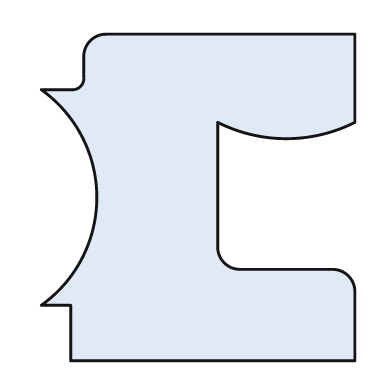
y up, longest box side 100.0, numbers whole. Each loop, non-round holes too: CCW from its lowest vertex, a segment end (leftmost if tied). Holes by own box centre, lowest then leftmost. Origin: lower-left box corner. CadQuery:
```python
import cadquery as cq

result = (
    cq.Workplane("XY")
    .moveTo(9.0, 0.0)
    .lineTo(96.0, 0.0)
    .lineTo(96.0, 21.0)
    .threePointArc((94.0, 26.0), (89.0, 28.0))
    .lineTo(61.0, 28.0)
    .threePointArc((56.0, 30.0), (54.0, 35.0))
    .lineTo(54.0, 73.0)
    .threePointArc((75.0, 68.0), (96.0, 73.0))
    .lineTo(96.0, 100.0)
    .lineTo(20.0, 100.0)
    .threePointArc((15.0, 98.0), (13.0, 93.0))
    .lineTo(13.0, 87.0)
    .threePointArc((12.0, 84.0), (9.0, 83.0))
    .lineTo(0.0, 83.0)
    .threePointArc((17.0, 50.0), (0.0, 17.0))
    .lineTo(9.0, 17.0)
    .close()
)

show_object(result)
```